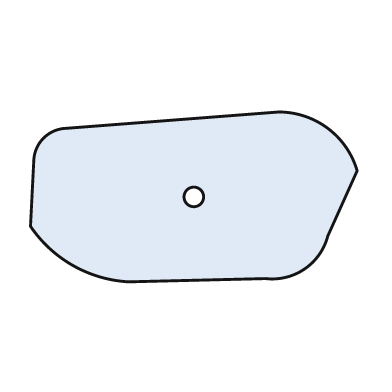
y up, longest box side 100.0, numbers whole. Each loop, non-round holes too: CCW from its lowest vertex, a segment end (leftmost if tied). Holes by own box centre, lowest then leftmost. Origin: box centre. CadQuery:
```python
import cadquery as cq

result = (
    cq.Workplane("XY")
    .moveTo(-20.0, -26.0)
    .lineTo(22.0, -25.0)
    .threePointArc((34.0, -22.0), (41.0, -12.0))
    .lineTo(50.0, 8.0)
    .threePointArc((41.0, 21.0), (26.0, 26.0))
    .lineTo(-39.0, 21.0)
    .threePointArc((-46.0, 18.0), (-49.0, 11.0))
    .lineTo(-50.0, -9.0)
    .threePointArc((-37.0, -21.0), (-20.0, -26.0))
    .close()
    .moveTo(0.0, 0.0)
    .circle(3.0)
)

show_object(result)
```